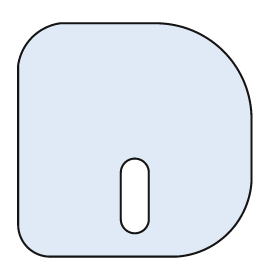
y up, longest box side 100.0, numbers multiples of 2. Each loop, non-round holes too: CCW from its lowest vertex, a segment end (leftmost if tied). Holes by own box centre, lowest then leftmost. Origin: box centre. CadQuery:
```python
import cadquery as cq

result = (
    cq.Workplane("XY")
    .moveTo(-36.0, -50.0)
    .lineTo(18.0, -50.0)
    .threePointArc((40.0, -40.0), (50.0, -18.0))
    .lineTo(50.0, 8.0)
    .threePointArc((38.0, 38.0), (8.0, 50.0))
    .lineTo(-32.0, 50.0)
    .threePointArc((-44.0, 44.0), (-50.0, 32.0))
    .lineTo(-50.0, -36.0)
    .threePointArc((-46.0, -46.0), (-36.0, -50.0))
    .close()
    .moveTo(-6.0, -34.0)
    .threePointArc((0.0, -40.0), (6.0, -34.0))
    .lineTo(6.0, -14.0)
    .threePointArc((0.0, -8.0), (-6.0, -14.0))
    .close()
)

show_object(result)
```